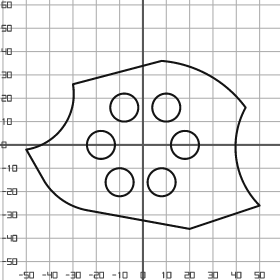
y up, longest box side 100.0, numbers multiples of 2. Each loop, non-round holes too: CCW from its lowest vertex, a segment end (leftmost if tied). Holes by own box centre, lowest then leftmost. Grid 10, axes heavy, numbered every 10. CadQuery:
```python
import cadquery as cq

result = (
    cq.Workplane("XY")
    .moveTo(20.0, -36.0)
    .lineTo(50.0, -26.0)
    .threePointArc((40.0, -6.0), (44.0, 16.0))
    .threePointArc((28.0, 30.0), (8.0, 36.0))
    .lineTo(-30.0, 26.0)
    .threePointArc((-34.0, 8.0), (-50.0, -2.0))
    .lineTo(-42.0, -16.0)
    .threePointArc((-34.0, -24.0), (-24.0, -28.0))
    .close()
    .moveTo(-10.0, -16.0)
    .circle(6.0)
    .moveTo(8.0, -16.0)
    .circle(6.0)
    .moveTo(-18.0, 0.0)
    .circle(6.0)
    .moveTo(18.0, 0.0)
    .circle(6.0)
    .moveTo(-8.0, 16.0)
    .circle(6.0)
    .moveTo(10.0, 16.0)
    .circle(6.0)
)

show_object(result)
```